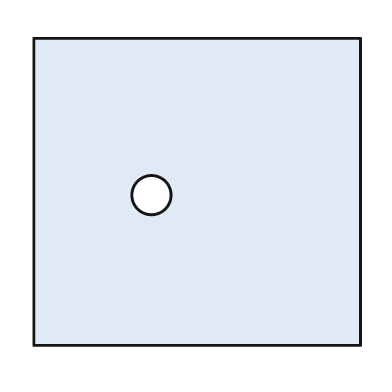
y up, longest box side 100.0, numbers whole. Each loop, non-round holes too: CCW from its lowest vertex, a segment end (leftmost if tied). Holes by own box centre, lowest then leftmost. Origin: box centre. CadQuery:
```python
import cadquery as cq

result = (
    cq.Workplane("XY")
    .moveTo(-50.0, -47.0)
    .lineTo(50.0, -47.0)
    .lineTo(50.0, 47.0)
    .lineTo(-50.0, 47.0)
    .close()
    .moveTo(-14.0, -1.0)
    .circle(6.0)
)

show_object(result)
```